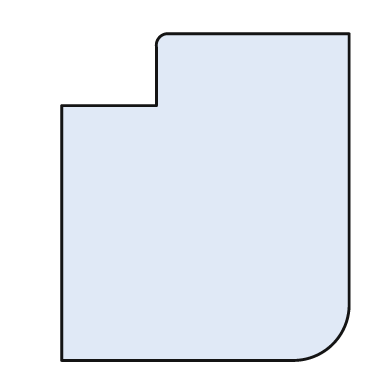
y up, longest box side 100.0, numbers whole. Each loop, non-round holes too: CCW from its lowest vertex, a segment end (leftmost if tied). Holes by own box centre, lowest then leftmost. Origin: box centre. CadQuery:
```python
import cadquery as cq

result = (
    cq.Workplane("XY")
    .moveTo(-44.0, -50.0)
    .lineTo(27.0, -50.0)
    .threePointArc((39.0, -45.0), (44.0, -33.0))
    .lineTo(44.0, 50.0)
    .lineTo(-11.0, 50.0)
    .threePointArc((-14.0, 49.0), (-15.0, 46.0))
    .lineTo(-15.0, 28.0)
    .lineTo(-44.0, 28.0)
    .close()
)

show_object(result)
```